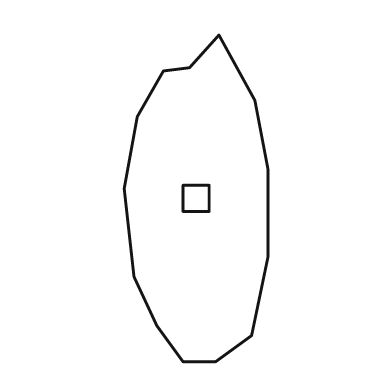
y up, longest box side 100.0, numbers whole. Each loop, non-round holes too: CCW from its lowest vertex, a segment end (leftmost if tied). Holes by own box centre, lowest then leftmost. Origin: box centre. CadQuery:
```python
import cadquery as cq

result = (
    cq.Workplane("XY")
    .moveTo(-4.0, -50.0)
    .lineTo(6.0, -50.0)
    .lineTo(17.0, -42.0)
    .lineTo(22.0, -18.0)
    .lineTo(22.0, 9.0)
    .lineTo(18.0, 30.0)
    .lineTo(7.0, 50.0)
    .lineTo(-2.0, 40.0)
    .lineTo(-10.0, 39.0)
    .lineTo(-18.0, 25.0)
    .lineTo(-22.0, 3.0)
    .lineTo(-19.0, -24.0)
    .lineTo(-12.0, -39.0)
    .close()
    .moveTo(-4.0, -4.0)
    .lineTo(4.0, -4.0)
    .lineTo(4.0, 4.0)
    .lineTo(-4.0, 4.0)
    .close()
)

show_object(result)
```